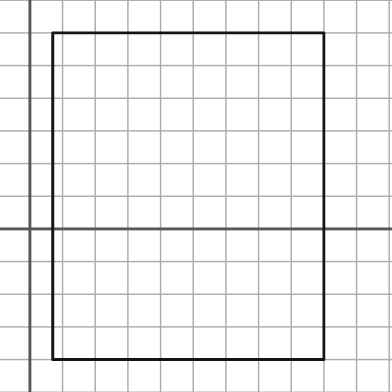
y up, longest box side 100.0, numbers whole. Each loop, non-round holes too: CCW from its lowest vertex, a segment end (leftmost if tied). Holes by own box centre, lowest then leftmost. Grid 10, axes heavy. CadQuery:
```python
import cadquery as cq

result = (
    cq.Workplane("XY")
    .moveTo(7.0, -40.0)
    .lineTo(90.0, -40.0)
    .lineTo(90.0, 60.0)
    .lineTo(7.0, 60.0)
    .close()
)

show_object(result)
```